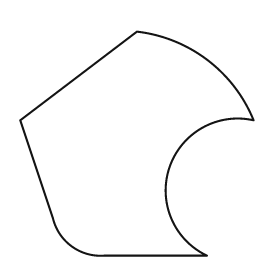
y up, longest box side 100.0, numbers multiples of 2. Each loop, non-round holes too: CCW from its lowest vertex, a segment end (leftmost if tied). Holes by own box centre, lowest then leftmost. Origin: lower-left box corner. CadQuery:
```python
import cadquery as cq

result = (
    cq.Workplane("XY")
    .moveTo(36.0, 0.0)
    .lineTo(80.0, 0.0)
    .threePointArc((64.0, 38.0), (100.0, 58.0))
    .threePointArc((80.0, 84.0), (50.0, 96.0))
    .lineTo(0.0, 58.0)
    .lineTo(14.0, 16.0)
    .threePointArc((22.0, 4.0), (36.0, 0.0))
    .close()
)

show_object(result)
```